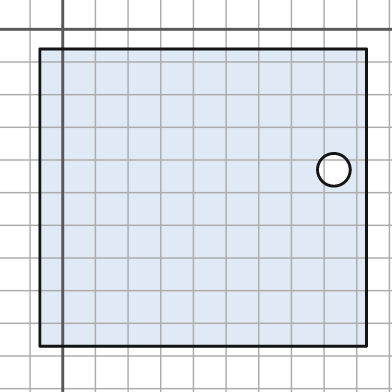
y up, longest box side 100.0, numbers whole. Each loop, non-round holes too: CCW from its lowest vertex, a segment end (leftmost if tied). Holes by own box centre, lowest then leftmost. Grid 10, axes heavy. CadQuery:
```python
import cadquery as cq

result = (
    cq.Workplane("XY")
    .moveTo(-7.0, -97.0)
    .lineTo(93.0, -97.0)
    .lineTo(93.0, -6.0)
    .lineTo(-7.0, -6.0)
    .close()
    .moveTo(83.0, -43.0)
    .circle(5.0)
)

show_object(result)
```